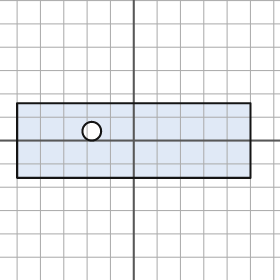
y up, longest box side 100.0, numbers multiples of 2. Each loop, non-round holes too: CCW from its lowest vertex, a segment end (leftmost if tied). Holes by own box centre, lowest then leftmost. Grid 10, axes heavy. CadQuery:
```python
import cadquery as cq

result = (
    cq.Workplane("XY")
    .moveTo(-50.0, -16.0)
    .lineTo(50.0, -16.0)
    .lineTo(50.0, 16.0)
    .lineTo(-50.0, 16.0)
    .close()
    .moveTo(-18.0, 4.0)
    .circle(4.0)
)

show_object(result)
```